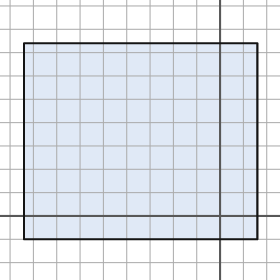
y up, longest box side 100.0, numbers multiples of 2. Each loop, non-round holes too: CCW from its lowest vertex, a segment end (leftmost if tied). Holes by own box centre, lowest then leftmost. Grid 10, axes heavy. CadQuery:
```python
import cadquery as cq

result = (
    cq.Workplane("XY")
    .moveTo(-84.0, -10.0)
    .lineTo(16.0, -10.0)
    .lineTo(16.0, 74.0)
    .lineTo(-84.0, 74.0)
    .close()
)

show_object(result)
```